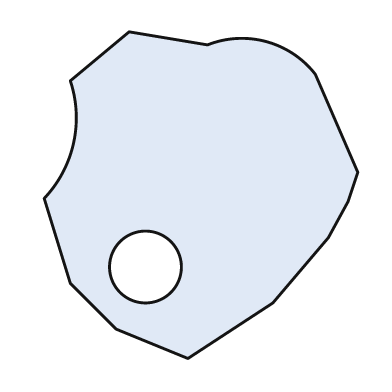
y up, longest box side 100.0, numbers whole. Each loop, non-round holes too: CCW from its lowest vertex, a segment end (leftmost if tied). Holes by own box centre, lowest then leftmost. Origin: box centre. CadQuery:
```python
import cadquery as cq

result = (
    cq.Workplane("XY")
    .moveTo(-4.0, -50.0)
    .lineTo(22.0, -33.0)
    .lineTo(39.0, -13.0)
    .lineTo(45.0, -2.0)
    .lineTo(48.0, 7.0)
    .lineTo(35.0, 37.0)
    .threePointArc((20.0, 47.0), (2.0, 46.0))
    .lineTo(-22.0, 50.0)
    .lineTo(-40.0, 35.0)
    .threePointArc((-39.0, 16.0), (-48.0, -1.0))
    .lineTo(-40.0, -27.0)
    .lineTo(-26.0, -41.0)
    .close()
    .moveTo(-17.0, -22.0)
    .circle(11.0)
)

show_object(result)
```